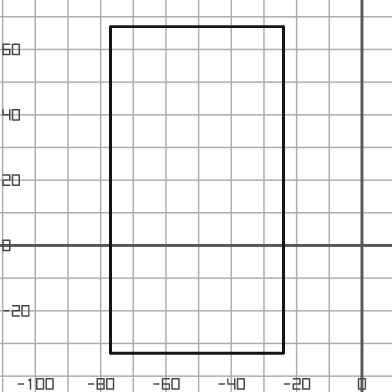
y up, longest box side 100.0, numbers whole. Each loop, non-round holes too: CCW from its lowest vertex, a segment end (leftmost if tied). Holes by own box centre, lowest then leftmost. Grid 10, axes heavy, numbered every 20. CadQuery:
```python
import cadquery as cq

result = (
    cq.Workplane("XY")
    .moveTo(-77.0, -33.0)
    .lineTo(-24.0, -33.0)
    .lineTo(-24.0, 67.0)
    .lineTo(-77.0, 67.0)
    .close()
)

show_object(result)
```